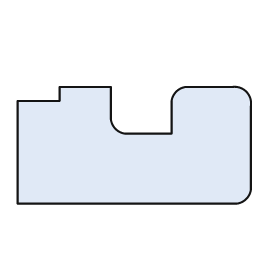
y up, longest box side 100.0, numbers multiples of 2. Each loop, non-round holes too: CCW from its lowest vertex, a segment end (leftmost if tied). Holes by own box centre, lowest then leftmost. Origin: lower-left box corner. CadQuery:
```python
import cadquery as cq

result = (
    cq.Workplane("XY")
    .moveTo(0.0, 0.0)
    .lineTo(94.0, 0.0)
    .threePointArc((98.0, 2.0), (100.0, 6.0))
    .lineTo(100.0, 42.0)
    .threePointArc((98.0, 48.0), (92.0, 50.0))
    .lineTo(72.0, 50.0)
    .threePointArc((68.0, 48.0), (66.0, 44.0))
    .lineTo(66.0, 30.0)
    .lineTo(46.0, 30.0)
    .threePointArc((42.0, 32.0), (40.0, 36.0))
    .lineTo(40.0, 50.0)
    .lineTo(18.0, 50.0)
    .lineTo(18.0, 44.0)
    .lineTo(0.0, 44.0)
    .close()
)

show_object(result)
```